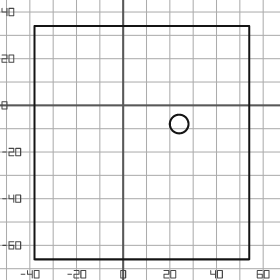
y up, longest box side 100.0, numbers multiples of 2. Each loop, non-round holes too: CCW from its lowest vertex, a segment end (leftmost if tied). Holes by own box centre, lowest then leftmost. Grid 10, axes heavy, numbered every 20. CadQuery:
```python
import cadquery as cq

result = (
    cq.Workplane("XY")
    .moveTo(-38.0, -66.0)
    .lineTo(54.0, -66.0)
    .lineTo(54.0, 34.0)
    .lineTo(-38.0, 34.0)
    .close()
    .moveTo(24.0, -8.0)
    .circle(4.0)
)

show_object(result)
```